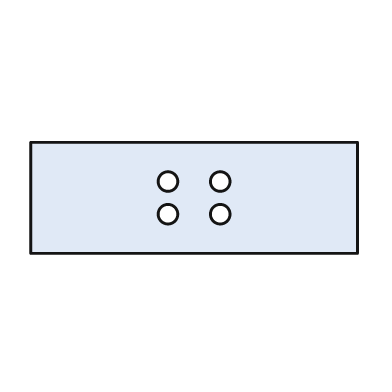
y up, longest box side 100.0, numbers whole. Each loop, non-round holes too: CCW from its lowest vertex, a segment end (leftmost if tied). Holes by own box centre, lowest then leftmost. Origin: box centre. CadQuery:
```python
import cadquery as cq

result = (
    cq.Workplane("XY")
    .moveTo(-50.0, -17.0)
    .lineTo(50.0, -17.0)
    .lineTo(50.0, 17.0)
    .lineTo(-50.0, 17.0)
    .close()
    .moveTo(-8.0, -5.0)
    .circle(3.0)
    .moveTo(8.0, -5.0)
    .circle(3.0)
    .moveTo(-8.0, 5.0)
    .circle(3.0)
    .moveTo(8.0, 5.0)
    .circle(3.0)
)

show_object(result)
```